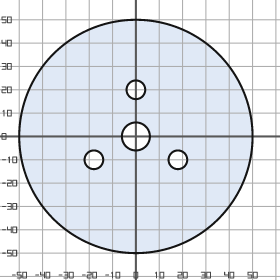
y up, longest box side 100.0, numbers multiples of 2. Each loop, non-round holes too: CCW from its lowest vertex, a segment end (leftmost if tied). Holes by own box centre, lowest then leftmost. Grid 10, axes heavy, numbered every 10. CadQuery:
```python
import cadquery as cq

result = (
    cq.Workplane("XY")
    .moveTo(0.0, 0.0)
    .circle(50.0)
    .moveTo(-18.0, -10.0)
    .circle(4.0)
    .moveTo(18.0, -10.0)
    .circle(4.0)
    .moveTo(0.0, 0.0)
    .circle(6.0)
    .moveTo(0.0, 20.0)
    .circle(4.0)
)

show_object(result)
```